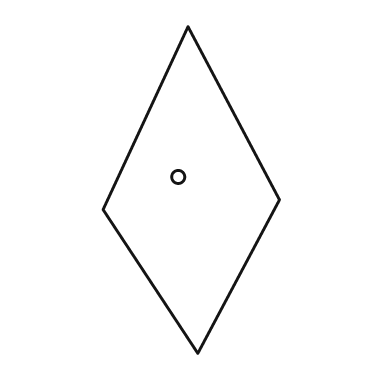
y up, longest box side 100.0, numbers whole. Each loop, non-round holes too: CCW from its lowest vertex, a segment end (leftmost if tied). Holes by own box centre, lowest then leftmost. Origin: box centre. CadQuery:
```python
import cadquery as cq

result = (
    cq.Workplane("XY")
    .moveTo(2.0, -50.0)
    .lineTo(27.0, -3.0)
    .lineTo(-1.0, 50.0)
    .lineTo(-27.0, -6.0)
    .close()
    .moveTo(-4.0, 4.0)
    .circle(2.0)
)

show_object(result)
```